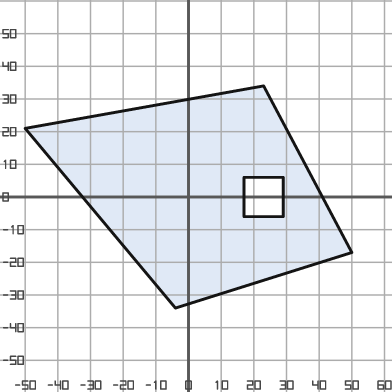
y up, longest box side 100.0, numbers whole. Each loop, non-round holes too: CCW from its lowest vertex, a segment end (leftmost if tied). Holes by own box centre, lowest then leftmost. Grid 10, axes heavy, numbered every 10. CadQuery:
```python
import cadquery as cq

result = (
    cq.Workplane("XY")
    .moveTo(-4.0, -34.0)
    .lineTo(50.0, -17.0)
    .lineTo(23.0, 34.0)
    .lineTo(-50.0, 21.0)
    .close()
    .moveTo(17.0, -6.0)
    .lineTo(29.0, -6.0)
    .lineTo(29.0, 6.0)
    .lineTo(17.0, 6.0)
    .close()
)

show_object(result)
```